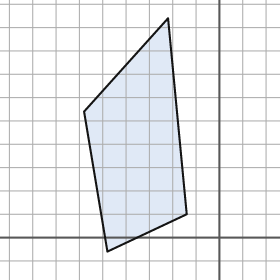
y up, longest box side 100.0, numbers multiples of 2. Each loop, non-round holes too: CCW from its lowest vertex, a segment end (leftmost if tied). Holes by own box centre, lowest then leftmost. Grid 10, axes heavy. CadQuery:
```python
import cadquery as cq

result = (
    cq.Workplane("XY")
    .moveTo(-48.0, -6.0)
    .lineTo(-14.0, 10.0)
    .lineTo(-22.0, 94.0)
    .lineTo(-58.0, 54.0)
    .close()
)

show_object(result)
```